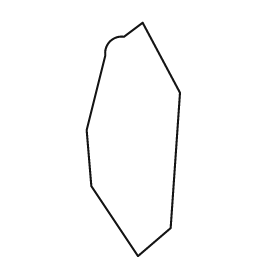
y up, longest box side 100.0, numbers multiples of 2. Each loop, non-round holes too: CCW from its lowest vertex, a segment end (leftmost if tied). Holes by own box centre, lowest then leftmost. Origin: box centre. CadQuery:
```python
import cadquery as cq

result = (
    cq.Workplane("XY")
    .moveTo(2.0, -50.0)
    .lineTo(16.0, -38.0)
    .lineTo(20.0, 20.0)
    .lineTo(4.0, 50.0)
    .lineTo(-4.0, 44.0)
    .threePointArc((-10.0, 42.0), (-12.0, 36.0))
    .lineTo(-20.0, 4.0)
    .lineTo(-18.0, -20.0)
    .close()
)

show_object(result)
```